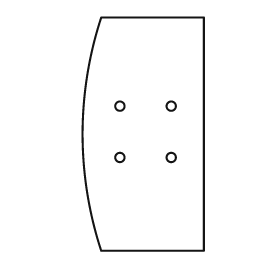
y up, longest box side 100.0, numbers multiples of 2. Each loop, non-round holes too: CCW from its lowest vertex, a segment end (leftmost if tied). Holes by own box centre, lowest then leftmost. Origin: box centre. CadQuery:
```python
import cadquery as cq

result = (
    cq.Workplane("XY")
    .moveTo(-18.0, -50.0)
    .lineTo(26.0, -50.0)
    .lineTo(26.0, 50.0)
    .lineTo(-18.0, 50.0)
    .threePointArc((-26.0, 0.0), (-18.0, -50.0))
    .close()
    .moveTo(-10.0, -10.0)
    .circle(2.0)
    .moveTo(12.0, -10.0)
    .circle(2.0)
    .moveTo(-10.0, 12.0)
    .circle(2.0)
    .moveTo(12.0, 12.0)
    .circle(2.0)
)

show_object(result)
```